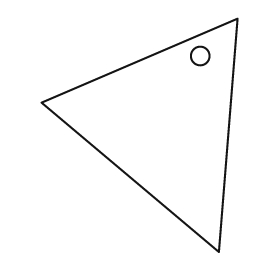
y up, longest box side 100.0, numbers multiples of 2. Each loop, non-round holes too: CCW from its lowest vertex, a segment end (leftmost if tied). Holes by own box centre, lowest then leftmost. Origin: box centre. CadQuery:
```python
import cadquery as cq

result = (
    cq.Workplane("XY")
    .moveTo(34.0, -50.0)
    .lineTo(42.0, 50.0)
    .lineTo(-42.0, 14.0)
    .close()
    .moveTo(26.0, 34.0)
    .circle(4.0)
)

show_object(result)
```